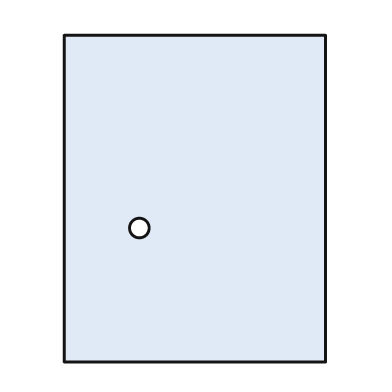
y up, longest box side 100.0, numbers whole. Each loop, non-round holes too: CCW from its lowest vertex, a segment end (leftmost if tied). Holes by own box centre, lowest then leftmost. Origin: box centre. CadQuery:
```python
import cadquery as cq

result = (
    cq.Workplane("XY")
    .moveTo(-40.0, -50.0)
    .lineTo(40.0, -50.0)
    .lineTo(40.0, 50.0)
    .lineTo(-40.0, 50.0)
    .close()
    .moveTo(-17.0, -9.0)
    .circle(3.0)
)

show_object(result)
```